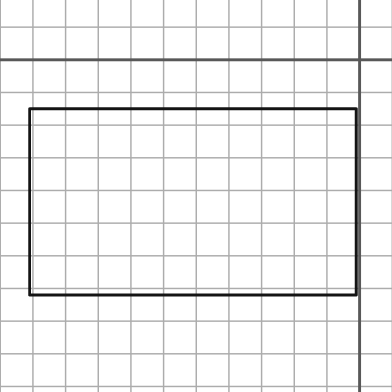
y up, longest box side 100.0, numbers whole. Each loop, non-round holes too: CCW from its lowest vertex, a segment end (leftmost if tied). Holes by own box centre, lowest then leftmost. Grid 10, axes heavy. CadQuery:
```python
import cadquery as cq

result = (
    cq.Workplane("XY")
    .moveTo(-101.0, -72.0)
    .lineTo(-1.0, -72.0)
    .lineTo(-1.0, -15.0)
    .lineTo(-101.0, -15.0)
    .close()
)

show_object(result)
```